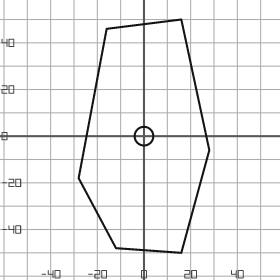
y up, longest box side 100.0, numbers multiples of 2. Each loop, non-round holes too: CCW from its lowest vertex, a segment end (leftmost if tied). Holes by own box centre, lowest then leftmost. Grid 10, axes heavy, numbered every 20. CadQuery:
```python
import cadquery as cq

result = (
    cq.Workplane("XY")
    .moveTo(16.0, -50.0)
    .lineTo(28.0, -6.0)
    .lineTo(16.0, 50.0)
    .lineTo(-16.0, 46.0)
    .lineTo(-28.0, -18.0)
    .lineTo(-12.0, -48.0)
    .close()
    .moveTo(0.0, 0.0)
    .circle(4.0)
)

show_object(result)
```